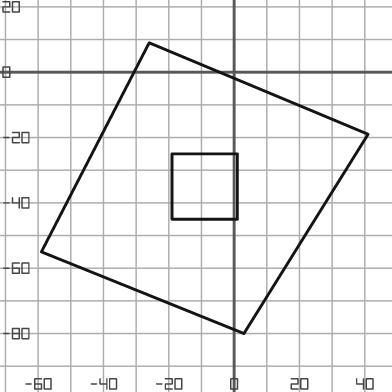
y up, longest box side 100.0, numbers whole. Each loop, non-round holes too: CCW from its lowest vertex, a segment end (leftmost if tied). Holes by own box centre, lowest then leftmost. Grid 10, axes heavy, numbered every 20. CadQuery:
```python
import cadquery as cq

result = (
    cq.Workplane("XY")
    .moveTo(3.0, -80.0)
    .lineTo(41.0, -19.0)
    .lineTo(-26.0, 9.0)
    .lineTo(-59.0, -55.0)
    .close()
    .moveTo(-19.0, -45.0)
    .lineTo(1.0, -45.0)
    .lineTo(1.0, -25.0)
    .lineTo(-19.0, -25.0)
    .close()
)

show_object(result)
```